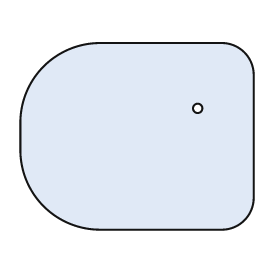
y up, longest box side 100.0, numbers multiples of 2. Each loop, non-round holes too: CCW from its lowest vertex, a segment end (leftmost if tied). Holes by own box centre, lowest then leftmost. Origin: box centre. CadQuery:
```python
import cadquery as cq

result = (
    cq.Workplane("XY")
    .moveTo(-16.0, -40.0)
    .lineTo(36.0, -40.0)
    .threePointArc((46.0, -36.0), (50.0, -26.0))
    .lineTo(50.0, 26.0)
    .threePointArc((46.0, 36.0), (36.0, 40.0))
    .lineTo(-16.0, 40.0)
    .threePointArc((-40.0, 30.0), (-50.0, 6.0))
    .lineTo(-50.0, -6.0)
    .threePointArc((-40.0, -30.0), (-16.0, -40.0))
    .close()
    .moveTo(26.0, 12.0)
    .circle(2.0)
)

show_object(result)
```